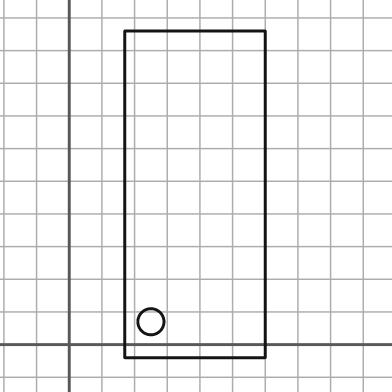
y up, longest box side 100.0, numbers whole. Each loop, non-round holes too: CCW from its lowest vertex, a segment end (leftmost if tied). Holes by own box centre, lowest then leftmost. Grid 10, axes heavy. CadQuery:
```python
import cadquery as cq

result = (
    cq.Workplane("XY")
    .moveTo(17.0, -4.0)
    .lineTo(60.0, -4.0)
    .lineTo(60.0, 96.0)
    .lineTo(17.0, 96.0)
    .close()
    .moveTo(25.0, 7.0)
    .circle(4.0)
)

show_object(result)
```